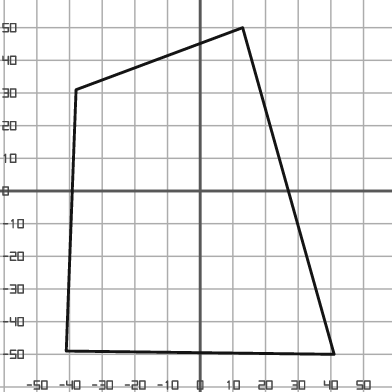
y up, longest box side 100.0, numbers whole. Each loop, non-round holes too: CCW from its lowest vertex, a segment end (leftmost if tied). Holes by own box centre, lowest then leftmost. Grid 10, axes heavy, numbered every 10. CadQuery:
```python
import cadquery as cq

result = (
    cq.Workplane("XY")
    .moveTo(41.0, -50.0)
    .lineTo(13.0, 50.0)
    .lineTo(-38.0, 31.0)
    .lineTo(-41.0, -49.0)
    .close()
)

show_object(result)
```